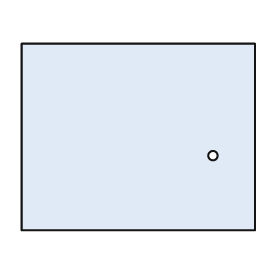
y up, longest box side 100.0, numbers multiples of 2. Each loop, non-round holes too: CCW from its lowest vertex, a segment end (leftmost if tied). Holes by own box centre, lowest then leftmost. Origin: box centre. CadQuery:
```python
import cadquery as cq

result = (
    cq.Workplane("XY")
    .moveTo(-50.0, -40.0)
    .lineTo(50.0, -40.0)
    .lineTo(50.0, 40.0)
    .lineTo(-50.0, 40.0)
    .close()
    .moveTo(32.0, -8.0)
    .circle(2.0)
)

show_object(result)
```